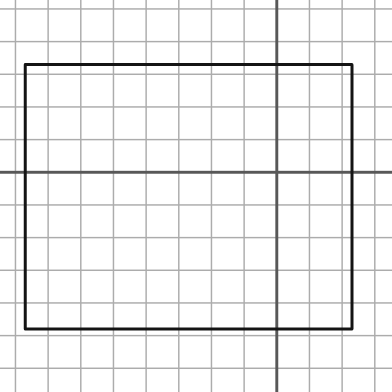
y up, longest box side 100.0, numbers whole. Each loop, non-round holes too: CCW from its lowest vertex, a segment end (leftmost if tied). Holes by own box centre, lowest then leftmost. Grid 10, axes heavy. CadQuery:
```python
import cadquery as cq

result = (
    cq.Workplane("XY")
    .moveTo(-77.0, -48.0)
    .lineTo(23.0, -48.0)
    .lineTo(23.0, 33.0)
    .lineTo(-77.0, 33.0)
    .close()
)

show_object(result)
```